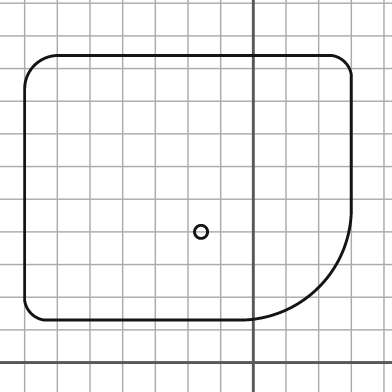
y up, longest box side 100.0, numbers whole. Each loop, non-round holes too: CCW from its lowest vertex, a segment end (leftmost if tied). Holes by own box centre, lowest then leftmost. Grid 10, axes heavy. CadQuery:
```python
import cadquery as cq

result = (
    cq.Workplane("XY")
    .moveTo(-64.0, 13.0)
    .lineTo(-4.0, 13.0)
    .threePointArc((20.0, 23.0), (30.0, 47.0))
    .lineTo(30.0, 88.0)
    .threePointArc((28.0, 92.0), (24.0, 94.0))
    .lineTo(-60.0, 94.0)
    .threePointArc((-67.0, 91.0), (-70.0, 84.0))
    .lineTo(-70.0, 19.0)
    .threePointArc((-68.0, 15.0), (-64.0, 13.0))
    .close()
    .moveTo(-16.0, 40.0)
    .circle(2.0)
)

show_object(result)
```